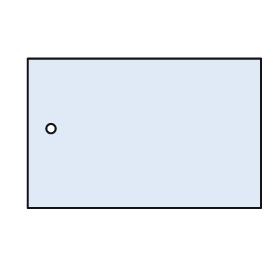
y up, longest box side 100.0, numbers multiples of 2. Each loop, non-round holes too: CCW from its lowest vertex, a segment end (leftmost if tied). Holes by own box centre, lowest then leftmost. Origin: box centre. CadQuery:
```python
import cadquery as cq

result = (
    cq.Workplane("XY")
    .moveTo(-50.0, -32.0)
    .lineTo(50.0, -32.0)
    .lineTo(50.0, 32.0)
    .lineTo(-50.0, 32.0)
    .close()
    .moveTo(-40.0, 2.0)
    .circle(2.0)
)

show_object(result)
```